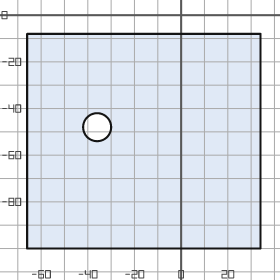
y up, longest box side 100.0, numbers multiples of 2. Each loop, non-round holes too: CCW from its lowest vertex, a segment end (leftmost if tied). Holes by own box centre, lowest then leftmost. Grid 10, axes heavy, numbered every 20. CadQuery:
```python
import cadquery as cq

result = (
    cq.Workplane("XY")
    .moveTo(-66.0, -100.0)
    .lineTo(34.0, -100.0)
    .lineTo(34.0, -8.0)
    .lineTo(-66.0, -8.0)
    .close()
    .moveTo(-36.0, -48.0)
    .circle(6.0)
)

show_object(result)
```